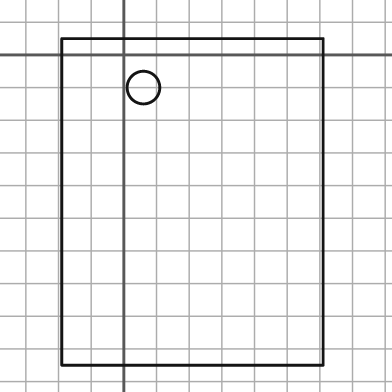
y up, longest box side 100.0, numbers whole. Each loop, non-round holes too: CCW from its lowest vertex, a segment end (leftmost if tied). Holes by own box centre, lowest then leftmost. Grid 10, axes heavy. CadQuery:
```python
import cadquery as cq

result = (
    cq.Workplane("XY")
    .moveTo(-19.0, -95.0)
    .lineTo(61.0, -95.0)
    .lineTo(61.0, 5.0)
    .lineTo(-19.0, 5.0)
    .close()
    .moveTo(6.0, -10.0)
    .circle(5.0)
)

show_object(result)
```